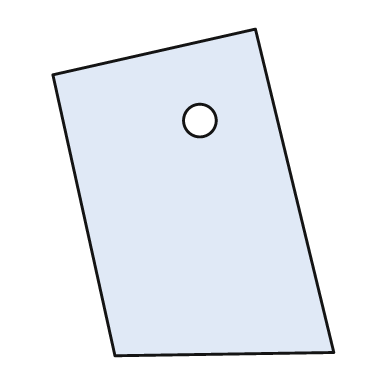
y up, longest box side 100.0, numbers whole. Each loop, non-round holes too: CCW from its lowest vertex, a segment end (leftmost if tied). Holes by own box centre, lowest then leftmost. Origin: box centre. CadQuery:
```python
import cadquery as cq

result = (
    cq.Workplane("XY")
    .moveTo(-24.0, -50.0)
    .lineTo(43.0, -49.0)
    .lineTo(19.0, 50.0)
    .lineTo(-43.0, 36.0)
    .close()
    .moveTo(2.0, 22.0)
    .circle(5.0)
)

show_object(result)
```